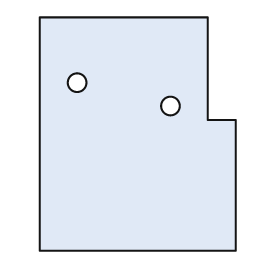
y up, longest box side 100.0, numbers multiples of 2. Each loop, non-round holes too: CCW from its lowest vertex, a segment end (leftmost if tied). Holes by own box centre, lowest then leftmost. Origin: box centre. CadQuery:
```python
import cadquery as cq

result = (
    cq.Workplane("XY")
    .moveTo(-42.0, -50.0)
    .lineTo(42.0, -50.0)
    .lineTo(42.0, 6.0)
    .lineTo(30.0, 6.0)
    .lineTo(30.0, 50.0)
    .lineTo(-42.0, 50.0)
    .close()
    .moveTo(14.0, 12.0)
    .circle(4.0)
    .moveTo(-26.0, 22.0)
    .circle(4.0)
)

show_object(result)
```